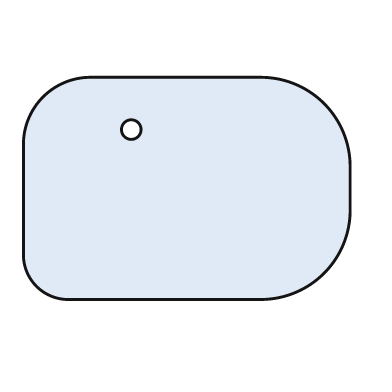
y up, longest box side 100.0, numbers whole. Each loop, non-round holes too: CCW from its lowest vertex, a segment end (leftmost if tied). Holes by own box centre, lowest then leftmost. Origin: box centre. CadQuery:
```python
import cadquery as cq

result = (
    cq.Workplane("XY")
    .moveTo(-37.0, -34.0)
    .lineTo(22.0, -34.0)
    .threePointArc((42.0, -26.0), (50.0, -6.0))
    .lineTo(50.0, 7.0)
    .threePointArc((42.0, 26.0), (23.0, 34.0))
    .lineTo(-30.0, 34.0)
    .threePointArc((-44.0, 28.0), (-50.0, 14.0))
    .lineTo(-50.0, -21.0)
    .threePointArc((-46.0, -30.0), (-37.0, -34.0))
    .close()
    .moveTo(-17.0, 18.0)
    .circle(3.0)
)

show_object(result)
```